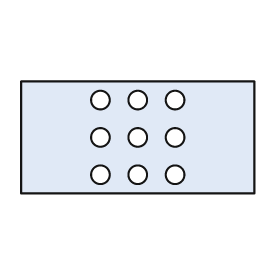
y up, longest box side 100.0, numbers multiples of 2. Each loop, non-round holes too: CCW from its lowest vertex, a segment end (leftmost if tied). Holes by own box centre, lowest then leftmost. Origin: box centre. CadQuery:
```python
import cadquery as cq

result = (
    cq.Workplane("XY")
    .moveTo(-50.0, -24.0)
    .lineTo(50.0, -24.0)
    .lineTo(50.0, 24.0)
    .lineTo(-50.0, 24.0)
    .close()
    .moveTo(-16.0, -16.0)
    .circle(4.0)
    .moveTo(0.0, -16.0)
    .circle(4.0)
    .moveTo(16.0, -16.0)
    .circle(4.0)
    .moveTo(-16.0, 0.0)
    .circle(4.0)
    .moveTo(0.0, 0.0)
    .circle(4.0)
    .moveTo(16.0, 0.0)
    .circle(4.0)
    .moveTo(-16.0, 16.0)
    .circle(4.0)
    .moveTo(0.0, 16.0)
    .circle(4.0)
    .moveTo(16.0, 16.0)
    .circle(4.0)
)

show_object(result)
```